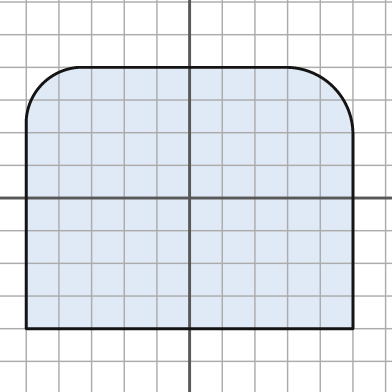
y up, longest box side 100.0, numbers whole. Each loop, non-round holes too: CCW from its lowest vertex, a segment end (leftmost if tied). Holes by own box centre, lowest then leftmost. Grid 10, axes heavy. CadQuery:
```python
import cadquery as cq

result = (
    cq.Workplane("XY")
    .moveTo(-50.0, -40.0)
    .lineTo(50.0, -40.0)
    .lineTo(50.0, 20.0)
    .threePointArc((44.0, 34.0), (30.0, 40.0))
    .lineTo(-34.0, 40.0)
    .threePointArc((-45.0, 35.0), (-50.0, 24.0))
    .close()
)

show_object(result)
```